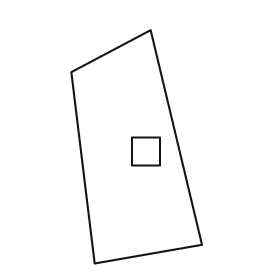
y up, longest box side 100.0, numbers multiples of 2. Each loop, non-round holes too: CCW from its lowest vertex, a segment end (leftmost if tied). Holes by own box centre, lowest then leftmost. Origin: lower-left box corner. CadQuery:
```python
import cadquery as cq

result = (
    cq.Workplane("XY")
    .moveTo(10.0, 0.0)
    .lineTo(56.0, 8.0)
    .lineTo(34.0, 100.0)
    .lineTo(0.0, 82.0)
    .close()
    .moveTo(26.0, 42.0)
    .lineTo(38.0, 42.0)
    .lineTo(38.0, 54.0)
    .lineTo(26.0, 54.0)
    .close()
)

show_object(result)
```